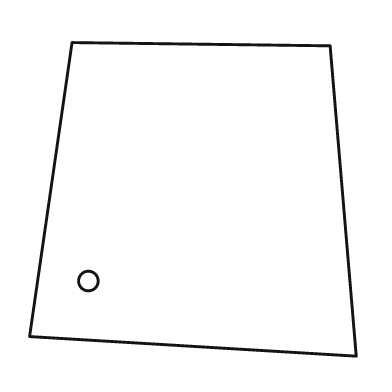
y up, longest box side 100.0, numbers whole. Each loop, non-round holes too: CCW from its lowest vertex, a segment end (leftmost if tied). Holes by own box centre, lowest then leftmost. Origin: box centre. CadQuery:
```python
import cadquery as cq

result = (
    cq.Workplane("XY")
    .moveTo(50.0, -48.0)
    .lineTo(42.0, 47.0)
    .lineTo(-37.0, 48.0)
    .lineTo(-50.0, -42.0)
    .close()
    .moveTo(-32.0, -25.0)
    .circle(3.0)
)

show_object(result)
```